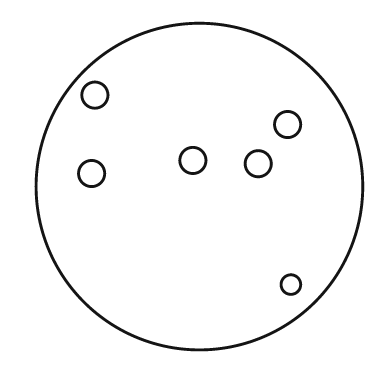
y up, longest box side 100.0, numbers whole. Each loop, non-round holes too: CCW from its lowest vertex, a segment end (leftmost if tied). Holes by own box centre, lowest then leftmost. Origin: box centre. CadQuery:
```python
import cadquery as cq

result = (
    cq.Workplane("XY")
    .moveTo(0.0, 0.0)
    .circle(50.0)
    .moveTo(28.0, -30.0)
    .circle(3.0)
    .moveTo(-33.0, 4.0)
    .circle(4.0)
    .moveTo(18.0, 7.0)
    .circle(4.0)
    .moveTo(-2.0, 8.0)
    .circle(4.0)
    .moveTo(27.0, 19.0)
    .circle(4.0)
    .moveTo(-32.0, 28.0)
    .circle(4.0)
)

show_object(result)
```